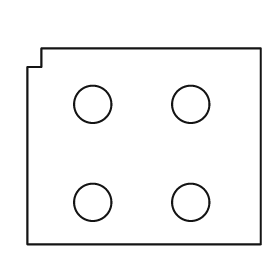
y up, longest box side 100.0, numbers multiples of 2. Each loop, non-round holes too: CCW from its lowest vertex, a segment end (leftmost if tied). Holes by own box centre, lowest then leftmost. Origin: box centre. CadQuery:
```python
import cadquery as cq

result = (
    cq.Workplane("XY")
    .moveTo(-50.0, -42.0)
    .lineTo(50.0, -42.0)
    .lineTo(50.0, 42.0)
    .lineTo(-44.0, 42.0)
    .lineTo(-44.0, 34.0)
    .lineTo(-50.0, 34.0)
    .close()
    .moveTo(-22.0, -24.0)
    .circle(8.0)
    .moveTo(20.0, -24.0)
    .circle(8.0)
    .moveTo(-22.0, 18.0)
    .circle(8.0)
    .moveTo(20.0, 18.0)
    .circle(8.0)
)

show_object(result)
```